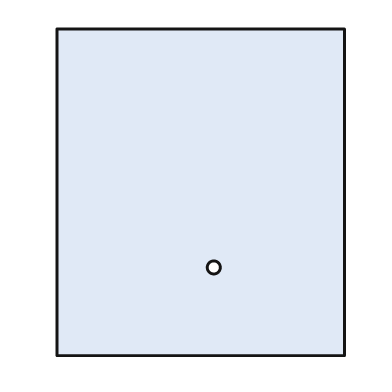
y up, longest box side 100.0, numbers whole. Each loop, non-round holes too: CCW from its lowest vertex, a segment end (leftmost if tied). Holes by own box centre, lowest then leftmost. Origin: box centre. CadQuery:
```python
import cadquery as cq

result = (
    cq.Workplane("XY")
    .moveTo(-44.0, -50.0)
    .lineTo(44.0, -50.0)
    .lineTo(44.0, 50.0)
    .lineTo(-44.0, 50.0)
    .close()
    .moveTo(4.0, -23.0)
    .circle(2.0)
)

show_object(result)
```